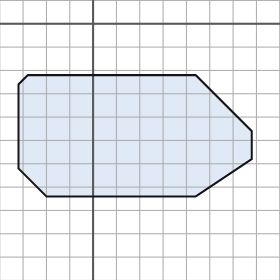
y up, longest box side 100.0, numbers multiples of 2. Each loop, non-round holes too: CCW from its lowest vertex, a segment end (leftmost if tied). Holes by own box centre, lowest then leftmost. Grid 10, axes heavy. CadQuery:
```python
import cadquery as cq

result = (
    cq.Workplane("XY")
    .moveTo(-20.0, -74.0)
    .lineTo(44.0, -74.0)
    .lineTo(68.0, -58.0)
    .lineTo(68.0, -46.0)
    .lineTo(44.0, -22.0)
    .lineTo(-28.0, -22.0)
    .lineTo(-32.0, -26.0)
    .lineTo(-32.0, -62.0)
    .close()
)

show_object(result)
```